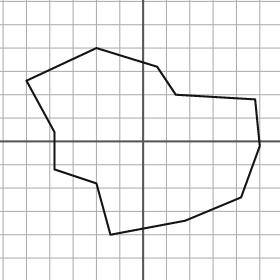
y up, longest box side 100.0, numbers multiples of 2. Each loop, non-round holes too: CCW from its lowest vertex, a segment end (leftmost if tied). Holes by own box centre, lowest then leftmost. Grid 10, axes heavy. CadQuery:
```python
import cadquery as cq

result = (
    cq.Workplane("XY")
    .moveTo(-14.0, -40.0)
    .lineTo(18.0, -34.0)
    .lineTo(42.0, -24.0)
    .lineTo(50.0, -2.0)
    .lineTo(48.0, 18.0)
    .lineTo(14.0, 20.0)
    .lineTo(6.0, 32.0)
    .lineTo(-20.0, 40.0)
    .lineTo(-50.0, 26.0)
    .lineTo(-38.0, 4.0)
    .lineTo(-38.0, -12.0)
    .lineTo(-20.0, -18.0)
    .close()
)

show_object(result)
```